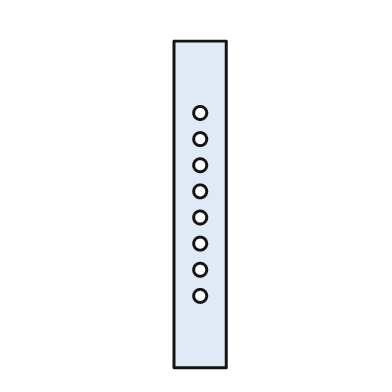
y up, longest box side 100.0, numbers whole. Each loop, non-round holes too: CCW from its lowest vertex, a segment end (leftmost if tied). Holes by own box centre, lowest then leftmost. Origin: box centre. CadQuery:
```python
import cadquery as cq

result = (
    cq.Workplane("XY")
    .moveTo(-8.0, -50.0)
    .lineTo(8.0, -50.0)
    .lineTo(8.0, 50.0)
    .lineTo(-8.0, 50.0)
    .close()
    .moveTo(0.0, -28.0)
    .circle(2.0)
    .moveTo(0.0, -20.0)
    .circle(2.0)
    .moveTo(0.0, -12.0)
    .circle(2.0)
    .moveTo(0.0, -4.0)
    .circle(2.0)
    .moveTo(0.0, 4.0)
    .circle(2.0)
    .moveTo(0.0, 12.0)
    .circle(2.0)
    .moveTo(0.0, 20.0)
    .circle(2.0)
    .moveTo(0.0, 28.0)
    .circle(2.0)
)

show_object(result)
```